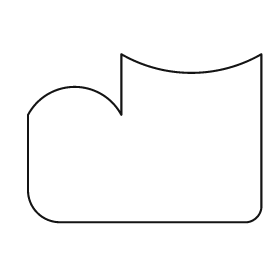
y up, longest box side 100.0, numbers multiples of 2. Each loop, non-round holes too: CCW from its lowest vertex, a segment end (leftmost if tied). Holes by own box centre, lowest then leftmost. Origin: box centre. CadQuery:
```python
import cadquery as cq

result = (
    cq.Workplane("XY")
    .moveTo(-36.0, -36.0)
    .lineTo(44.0, -36.0)
    .threePointArc((48.0, -34.0), (50.0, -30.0))
    .lineTo(50.0, 36.0)
    .threePointArc((20.0, 28.0), (-10.0, 36.0))
    .lineTo(-10.0, 10.0)
    .threePointArc((-30.0, 22.0), (-50.0, 10.0))
    .lineTo(-50.0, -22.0)
    .threePointArc((-46.0, -32.0), (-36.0, -36.0))
    .close()
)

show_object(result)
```